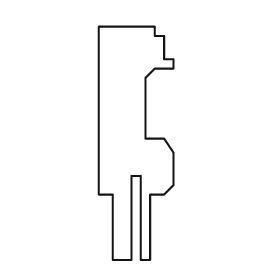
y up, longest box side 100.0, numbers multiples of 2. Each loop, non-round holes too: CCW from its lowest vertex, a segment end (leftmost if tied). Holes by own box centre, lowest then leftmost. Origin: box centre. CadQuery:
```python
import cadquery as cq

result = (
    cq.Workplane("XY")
    .moveTo(-10.0, -50.0)
    .lineTo(-2.0, -50.0)
    .lineTo(-2.0, -14.0)
    .lineTo(2.0, -14.0)
    .lineTo(2.0, -50.0)
    .lineTo(6.0, -50.0)
    .lineTo(6.0, -22.0)
    .lineTo(12.0, -22.0)
    .lineTo(16.0, -18.0)
    .lineTo(16.0, -4.0)
    .lineTo(12.0, 2.0)
    .lineTo(4.0, 2.0)
    .lineTo(4.0, 28.0)
    .lineTo(8.0, 32.0)
    .lineTo(16.0, 32.0)
    .lineTo(16.0, 36.0)
    .lineTo(12.0, 36.0)
    .lineTo(12.0, 46.0)
    .lineTo(8.0, 46.0)
    .lineTo(8.0, 50.0)
    .lineTo(-16.0, 50.0)
    .lineTo(-16.0, -22.0)
    .lineTo(-10.0, -22.0)
    .close()
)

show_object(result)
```